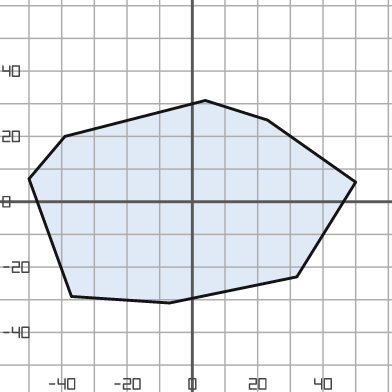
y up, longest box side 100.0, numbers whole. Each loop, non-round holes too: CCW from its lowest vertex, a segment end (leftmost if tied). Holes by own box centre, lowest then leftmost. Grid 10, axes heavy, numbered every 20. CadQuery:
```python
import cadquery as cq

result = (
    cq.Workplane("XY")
    .moveTo(-7.0, -31.0)
    .lineTo(32.0, -23.0)
    .lineTo(50.0, 6.0)
    .lineTo(23.0, 25.0)
    .lineTo(4.0, 31.0)
    .lineTo(-39.0, 20.0)
    .lineTo(-50.0, 7.0)
    .lineTo(-37.0, -29.0)
    .close()
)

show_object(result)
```